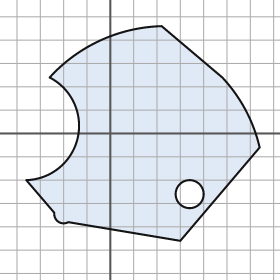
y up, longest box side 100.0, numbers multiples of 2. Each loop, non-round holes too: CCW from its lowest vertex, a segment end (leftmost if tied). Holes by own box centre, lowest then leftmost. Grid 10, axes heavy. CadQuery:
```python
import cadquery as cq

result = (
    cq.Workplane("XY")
    .moveTo(30.0, -46.0)
    .lineTo(64.0, -6.0)
    .threePointArc((58.0, 10.0), (48.0, 24.0))
    .lineTo(22.0, 46.0)
    .threePointArc((-4.0, 40.0), (-26.0, 24.0))
    .threePointArc((-14.0, -2.0), (-36.0, -20.0))
    .lineTo(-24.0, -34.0)
    .threePointArc((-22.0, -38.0), (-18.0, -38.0))
    .close()
    .moveTo(34.0, -26.0)
    .circle(6.0)
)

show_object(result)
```